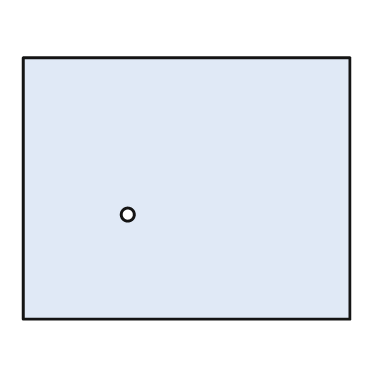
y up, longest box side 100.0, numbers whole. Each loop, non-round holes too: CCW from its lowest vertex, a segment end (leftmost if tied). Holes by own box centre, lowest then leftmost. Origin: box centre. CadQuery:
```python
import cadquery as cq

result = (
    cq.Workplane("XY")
    .moveTo(-50.0, -40.0)
    .lineTo(50.0, -40.0)
    .lineTo(50.0, 40.0)
    .lineTo(-50.0, 40.0)
    .close()
    .moveTo(-18.0, -8.0)
    .circle(2.0)
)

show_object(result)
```